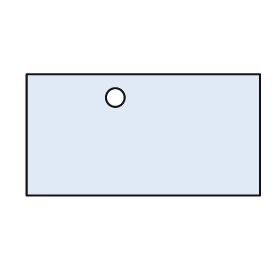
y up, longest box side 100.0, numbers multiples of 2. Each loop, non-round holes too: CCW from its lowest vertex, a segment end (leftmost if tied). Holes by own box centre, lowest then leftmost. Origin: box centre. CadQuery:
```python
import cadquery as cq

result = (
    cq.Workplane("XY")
    .moveTo(-50.0, -26.0)
    .lineTo(50.0, -26.0)
    .lineTo(50.0, 26.0)
    .lineTo(-50.0, 26.0)
    .close()
    .moveTo(-12.0, 16.0)
    .circle(4.0)
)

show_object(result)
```